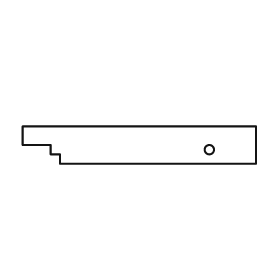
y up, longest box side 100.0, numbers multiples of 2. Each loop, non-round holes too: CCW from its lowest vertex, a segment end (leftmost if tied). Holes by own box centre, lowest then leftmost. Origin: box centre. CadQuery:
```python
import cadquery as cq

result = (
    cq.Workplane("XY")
    .moveTo(-34.0, -8.0)
    .lineTo(50.0, -8.0)
    .lineTo(50.0, 8.0)
    .lineTo(-50.0, 8.0)
    .lineTo(-50.0, 0.0)
    .lineTo(-38.0, 0.0)
    .lineTo(-38.0, -4.0)
    .lineTo(-34.0, -4.0)
    .close()
    .moveTo(30.0, -2.0)
    .circle(2.0)
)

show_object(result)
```